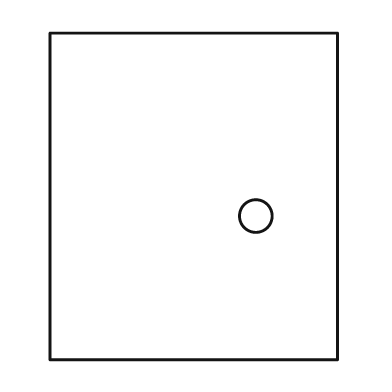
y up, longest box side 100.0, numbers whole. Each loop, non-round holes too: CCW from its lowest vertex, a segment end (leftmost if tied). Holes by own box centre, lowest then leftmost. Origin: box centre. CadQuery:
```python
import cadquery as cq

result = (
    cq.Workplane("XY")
    .moveTo(-44.0, -50.0)
    .lineTo(44.0, -50.0)
    .lineTo(44.0, 50.0)
    .lineTo(-44.0, 50.0)
    .close()
    .moveTo(19.0, -6.0)
    .circle(5.0)
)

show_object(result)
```